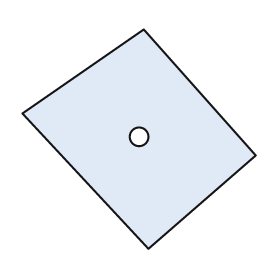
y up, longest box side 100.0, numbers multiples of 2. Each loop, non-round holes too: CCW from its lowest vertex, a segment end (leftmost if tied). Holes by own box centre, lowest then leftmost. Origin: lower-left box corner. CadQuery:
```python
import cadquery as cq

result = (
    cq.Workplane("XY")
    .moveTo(54.0, 0.0)
    .lineTo(100.0, 40.0)
    .lineTo(52.0, 94.0)
    .lineTo(0.0, 58.0)
    .close()
    .moveTo(50.0, 48.0)
    .circle(4.0)
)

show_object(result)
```